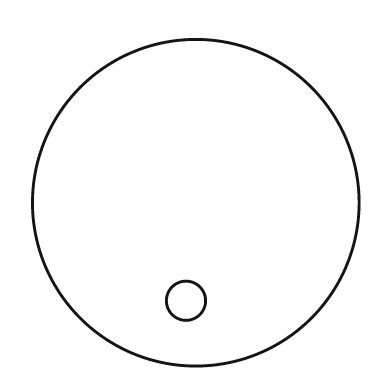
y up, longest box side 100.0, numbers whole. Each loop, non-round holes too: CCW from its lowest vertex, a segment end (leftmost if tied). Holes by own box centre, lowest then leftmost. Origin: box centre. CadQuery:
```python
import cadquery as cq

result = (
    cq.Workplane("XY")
    .moveTo(0.0, 0.0)
    .circle(50.0)
    .moveTo(-3.0, -30.0)
    .circle(6.0)
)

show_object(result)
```